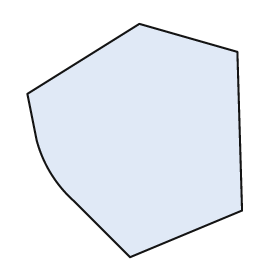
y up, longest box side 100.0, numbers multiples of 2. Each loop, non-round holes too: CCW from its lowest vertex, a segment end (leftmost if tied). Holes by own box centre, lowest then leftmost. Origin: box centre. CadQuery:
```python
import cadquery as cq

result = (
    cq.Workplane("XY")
    .moveTo(-2.0, -50.0)
    .lineTo(46.0, -30.0)
    .lineTo(44.0, 38.0)
    .lineTo(2.0, 50.0)
    .lineTo(-46.0, 20.0)
    .lineTo(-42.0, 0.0)
    .threePointArc((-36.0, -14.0), (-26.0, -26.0))
    .close()
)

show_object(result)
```